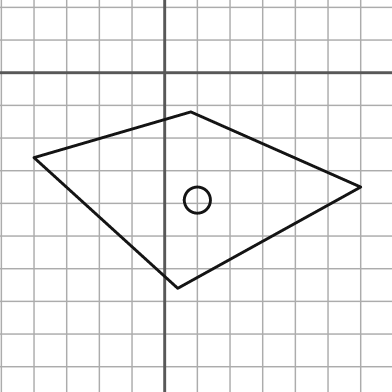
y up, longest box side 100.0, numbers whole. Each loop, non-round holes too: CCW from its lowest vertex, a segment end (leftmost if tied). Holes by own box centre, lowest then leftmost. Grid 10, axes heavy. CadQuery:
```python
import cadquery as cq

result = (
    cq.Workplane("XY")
    .moveTo(4.0, -66.0)
    .lineTo(60.0, -35.0)
    .lineTo(8.0, -12.0)
    .lineTo(-40.0, -26.0)
    .close()
    .moveTo(10.0, -39.0)
    .circle(4.0)
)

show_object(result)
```